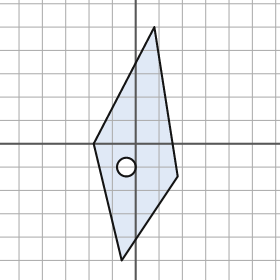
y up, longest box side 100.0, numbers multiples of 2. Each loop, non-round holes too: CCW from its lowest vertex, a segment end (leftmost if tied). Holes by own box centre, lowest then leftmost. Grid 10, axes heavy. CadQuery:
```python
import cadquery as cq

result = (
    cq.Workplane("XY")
    .moveTo(-6.0, -50.0)
    .lineTo(18.0, -14.0)
    .lineTo(8.0, 50.0)
    .lineTo(-18.0, 0.0)
    .close()
    .moveTo(-4.0, -10.0)
    .circle(4.0)
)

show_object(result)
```